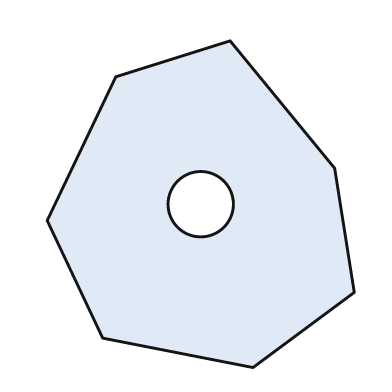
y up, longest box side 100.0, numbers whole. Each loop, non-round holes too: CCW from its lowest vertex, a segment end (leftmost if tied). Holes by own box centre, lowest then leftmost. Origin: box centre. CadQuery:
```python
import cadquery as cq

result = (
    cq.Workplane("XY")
    .moveTo(16.0, -50.0)
    .lineTo(47.0, -27.0)
    .lineTo(41.0, 11.0)
    .lineTo(9.0, 50.0)
    .lineTo(-26.0, 39.0)
    .lineTo(-47.0, -5.0)
    .lineTo(-30.0, -41.0)
    .close()
    .moveTo(0.0, 0.0)
    .circle(10.0)
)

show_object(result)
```